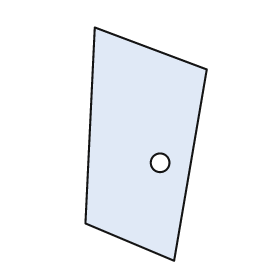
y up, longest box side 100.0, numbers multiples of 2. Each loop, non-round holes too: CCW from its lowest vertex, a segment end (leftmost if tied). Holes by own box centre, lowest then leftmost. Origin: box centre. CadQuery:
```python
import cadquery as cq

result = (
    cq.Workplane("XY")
    .moveTo(12.0, -50.0)
    .lineTo(26.0, 32.0)
    .lineTo(-22.0, 50.0)
    .lineTo(-26.0, -34.0)
    .close()
    .moveTo(6.0, -8.0)
    .circle(4.0)
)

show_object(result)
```